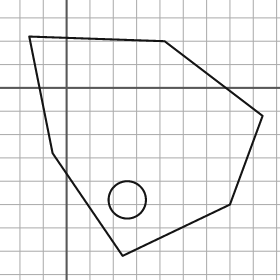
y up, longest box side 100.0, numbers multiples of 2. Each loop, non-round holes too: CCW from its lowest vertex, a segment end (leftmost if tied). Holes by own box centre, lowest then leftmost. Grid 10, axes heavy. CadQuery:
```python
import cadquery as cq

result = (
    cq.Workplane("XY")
    .moveTo(24.0, -72.0)
    .lineTo(70.0, -50.0)
    .lineTo(84.0, -12.0)
    .lineTo(42.0, 20.0)
    .lineTo(-16.0, 22.0)
    .lineTo(-6.0, -28.0)
    .close()
    .moveTo(26.0, -48.0)
    .circle(8.0)
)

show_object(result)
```